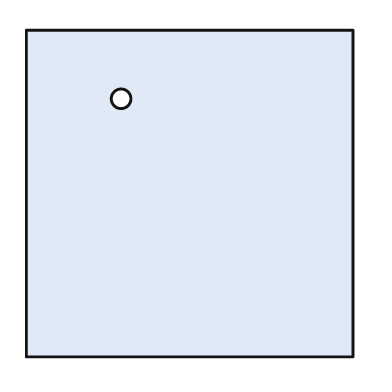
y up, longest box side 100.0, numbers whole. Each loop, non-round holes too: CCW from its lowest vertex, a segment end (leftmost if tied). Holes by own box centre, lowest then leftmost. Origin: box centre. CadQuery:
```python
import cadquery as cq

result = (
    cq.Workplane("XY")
    .moveTo(-50.0, -50.0)
    .lineTo(50.0, -50.0)
    .lineTo(50.0, 50.0)
    .lineTo(-50.0, 50.0)
    .close()
    .moveTo(-21.0, 29.0)
    .circle(3.0)
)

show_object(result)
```